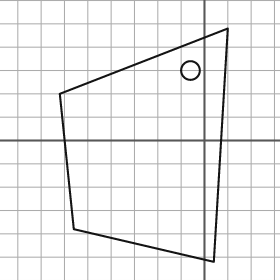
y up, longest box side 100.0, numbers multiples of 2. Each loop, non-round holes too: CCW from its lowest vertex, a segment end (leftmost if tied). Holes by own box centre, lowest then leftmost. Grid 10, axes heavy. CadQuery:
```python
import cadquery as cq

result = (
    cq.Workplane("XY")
    .moveTo(4.0, -52.0)
    .lineTo(10.0, 48.0)
    .lineTo(-62.0, 20.0)
    .lineTo(-56.0, -38.0)
    .close()
    .moveTo(-6.0, 30.0)
    .circle(4.0)
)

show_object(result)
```